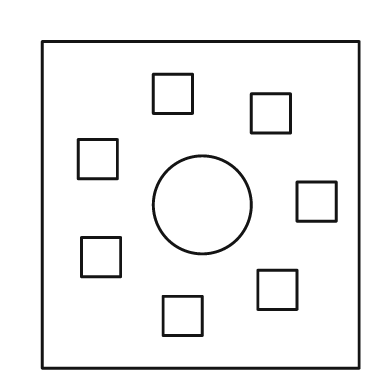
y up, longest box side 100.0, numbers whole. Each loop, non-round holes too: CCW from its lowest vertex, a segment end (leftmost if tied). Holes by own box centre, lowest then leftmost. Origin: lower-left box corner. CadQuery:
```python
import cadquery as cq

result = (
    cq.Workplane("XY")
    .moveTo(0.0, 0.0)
    .lineTo(97.0, 0.0)
    .lineTo(97.0, 100.0)
    .lineTo(0.0, 100.0)
    .close()
    .moveTo(37.0, 10.0)
    .lineTo(49.0, 10.0)
    .lineTo(49.0, 22.0)
    .lineTo(37.0, 22.0)
    .close()
    .moveTo(66.0, 18.0)
    .lineTo(78.0, 18.0)
    .lineTo(78.0, 30.0)
    .lineTo(66.0, 30.0)
    .close()
    .moveTo(12.0, 28.0)
    .lineTo(24.0, 28.0)
    .lineTo(24.0, 40.0)
    .lineTo(12.0, 40.0)
    .close()
    .moveTo(49.0, 50.0)
    .circle(15.0)
    .moveTo(78.0, 45.0)
    .lineTo(90.0, 45.0)
    .lineTo(90.0, 57.0)
    .lineTo(78.0, 57.0)
    .close()
    .moveTo(11.0, 58.0)
    .lineTo(23.0, 58.0)
    .lineTo(23.0, 70.0)
    .lineTo(11.0, 70.0)
    .close()
    .moveTo(64.0, 72.0)
    .lineTo(76.0, 72.0)
    .lineTo(76.0, 84.0)
    .lineTo(64.0, 84.0)
    .close()
    .moveTo(34.0, 78.0)
    .lineTo(46.0, 78.0)
    .lineTo(46.0, 90.0)
    .lineTo(34.0, 90.0)
    .close()
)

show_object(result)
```